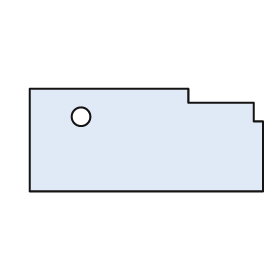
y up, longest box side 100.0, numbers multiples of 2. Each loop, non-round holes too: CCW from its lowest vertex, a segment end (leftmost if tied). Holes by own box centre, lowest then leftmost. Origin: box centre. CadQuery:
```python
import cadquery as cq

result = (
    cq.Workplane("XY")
    .moveTo(-50.0, -22.0)
    .lineTo(50.0, -22.0)
    .lineTo(50.0, 8.0)
    .lineTo(46.0, 8.0)
    .lineTo(46.0, 16.0)
    .lineTo(18.0, 16.0)
    .lineTo(18.0, 22.0)
    .lineTo(-50.0, 22.0)
    .close()
    .moveTo(-28.0, 10.0)
    .circle(4.0)
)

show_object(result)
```